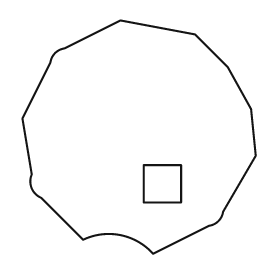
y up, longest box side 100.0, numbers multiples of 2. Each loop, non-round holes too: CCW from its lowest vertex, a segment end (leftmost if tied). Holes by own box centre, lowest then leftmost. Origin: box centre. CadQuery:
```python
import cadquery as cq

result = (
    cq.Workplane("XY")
    .moveTo(6.0, -50.0)
    .lineTo(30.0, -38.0)
    .threePointArc((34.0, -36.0), (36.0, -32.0))
    .lineTo(50.0, -8.0)
    .lineTo(48.0, 12.0)
    .lineTo(38.0, 30.0)
    .lineTo(24.0, 44.0)
    .lineTo(-8.0, 50.0)
    .lineTo(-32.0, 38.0)
    .threePointArc((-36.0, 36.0), (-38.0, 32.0))
    .lineTo(-50.0, 8.0)
    .lineTo(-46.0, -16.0)
    .threePointArc((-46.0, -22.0), (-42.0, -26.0))
    .lineTo(-24.0, -44.0)
    .threePointArc((-8.0, -42.0), (6.0, -50.0))
    .close()
    .moveTo(2.0, -28.0)
    .lineTo(18.0, -28.0)
    .lineTo(18.0, -12.0)
    .lineTo(2.0, -12.0)
    .close()
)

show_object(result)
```